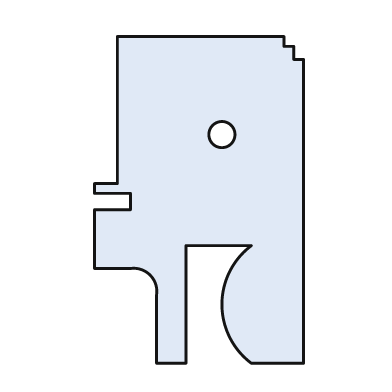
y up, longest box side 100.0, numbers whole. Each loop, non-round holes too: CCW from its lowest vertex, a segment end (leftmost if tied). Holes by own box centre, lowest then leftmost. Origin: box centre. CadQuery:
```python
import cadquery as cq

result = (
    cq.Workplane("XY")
    .moveTo(-13.0, -50.0)
    .lineTo(-4.0, -50.0)
    .lineTo(-4.0, -14.0)
    .lineTo(16.0, -14.0)
    .threePointArc((7.0, -32.0), (16.0, -50.0))
    .lineTo(32.0, -50.0)
    .lineTo(32.0, 43.0)
    .lineTo(29.0, 43.0)
    .lineTo(29.0, 47.0)
    .lineTo(26.0, 47.0)
    .lineTo(26.0, 50.0)
    .lineTo(-25.0, 50.0)
    .lineTo(-25.0, 5.0)
    .lineTo(-32.0, 5.0)
    .lineTo(-32.0, 2.0)
    .lineTo(-21.0, 2.0)
    .lineTo(-21.0, -3.0)
    .lineTo(-32.0, -3.0)
    .lineTo(-32.0, -21.0)
    .lineTo(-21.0, -21.0)
    .threePointArc((-15.0, -23.0), (-13.0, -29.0))
    .close()
    .moveTo(7.0, 20.0)
    .circle(4.0)
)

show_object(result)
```